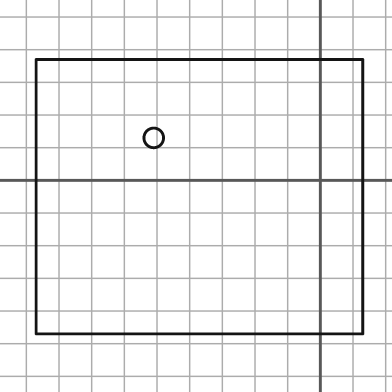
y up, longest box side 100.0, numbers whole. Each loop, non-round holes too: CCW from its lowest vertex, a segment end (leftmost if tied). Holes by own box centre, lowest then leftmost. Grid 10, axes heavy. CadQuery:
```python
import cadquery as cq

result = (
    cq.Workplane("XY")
    .moveTo(-87.0, -47.0)
    .lineTo(13.0, -47.0)
    .lineTo(13.0, 37.0)
    .lineTo(-87.0, 37.0)
    .close()
    .moveTo(-51.0, 13.0)
    .circle(3.0)
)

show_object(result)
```